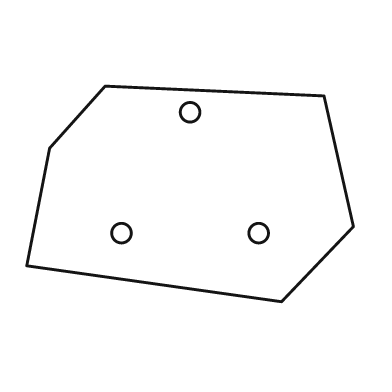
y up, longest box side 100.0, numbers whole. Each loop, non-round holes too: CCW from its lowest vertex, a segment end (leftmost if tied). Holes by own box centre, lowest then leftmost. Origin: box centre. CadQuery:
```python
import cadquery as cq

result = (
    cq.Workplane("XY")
    .moveTo(28.0, -33.0)
    .lineTo(50.0, -10.0)
    .lineTo(41.0, 30.0)
    .lineTo(-26.0, 33.0)
    .lineTo(-43.0, 14.0)
    .lineTo(-50.0, -22.0)
    .close()
    .moveTo(-21.0, -12.0)
    .circle(3.0)
    .moveTo(21.0, -12.0)
    .circle(3.0)
    .moveTo(0.0, 25.0)
    .circle(3.0)
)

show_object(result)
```